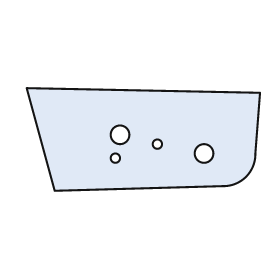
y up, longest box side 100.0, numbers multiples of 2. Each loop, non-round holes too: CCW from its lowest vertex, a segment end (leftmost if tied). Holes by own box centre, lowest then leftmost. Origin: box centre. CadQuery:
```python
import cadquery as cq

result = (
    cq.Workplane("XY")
    .moveTo(-38.0, -22.0)
    .lineTo(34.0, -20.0)
    .threePointArc((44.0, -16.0), (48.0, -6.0))
    .lineTo(50.0, 20.0)
    .lineTo(-50.0, 22.0)
    .close()
    .moveTo(-12.0, -8.0)
    .circle(2.0)
    .moveTo(26.0, -6.0)
    .circle(4.0)
    .moveTo(6.0, -2.0)
    .circle(2.0)
    .moveTo(-10.0, 2.0)
    .circle(4.0)
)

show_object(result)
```